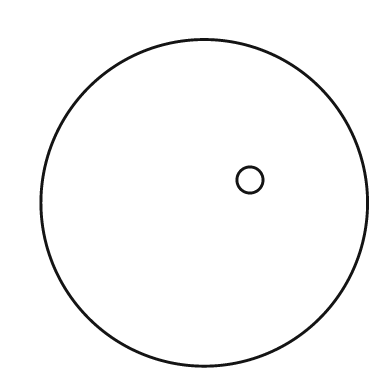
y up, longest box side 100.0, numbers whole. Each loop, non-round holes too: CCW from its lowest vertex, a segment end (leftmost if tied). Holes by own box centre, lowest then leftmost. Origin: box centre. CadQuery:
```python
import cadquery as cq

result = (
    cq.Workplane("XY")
    .moveTo(0.0, 0.0)
    .circle(50.0)
    .moveTo(14.0, 7.0)
    .circle(4.0)
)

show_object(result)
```